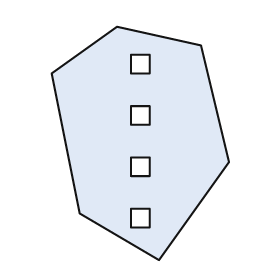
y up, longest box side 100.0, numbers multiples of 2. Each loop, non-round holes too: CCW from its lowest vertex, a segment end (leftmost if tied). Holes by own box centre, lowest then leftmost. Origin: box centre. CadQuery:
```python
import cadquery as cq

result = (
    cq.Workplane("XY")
    .moveTo(8.0, -50.0)
    .lineTo(38.0, -8.0)
    .lineTo(26.0, 42.0)
    .lineTo(-10.0, 50.0)
    .lineTo(-38.0, 30.0)
    .lineTo(-26.0, -30.0)
    .close()
    .moveTo(-4.0, -36.0)
    .lineTo(4.0, -36.0)
    .lineTo(4.0, -28.0)
    .lineTo(-4.0, -28.0)
    .close()
    .moveTo(-4.0, -14.0)
    .lineTo(4.0, -14.0)
    .lineTo(4.0, -6.0)
    .lineTo(-4.0, -6.0)
    .close()
    .moveTo(-4.0, 8.0)
    .lineTo(4.0, 8.0)
    .lineTo(4.0, 16.0)
    .lineTo(-4.0, 16.0)
    .close()
    .moveTo(-4.0, 30.0)
    .lineTo(4.0, 30.0)
    .lineTo(4.0, 38.0)
    .lineTo(-4.0, 38.0)
    .close()
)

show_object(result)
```